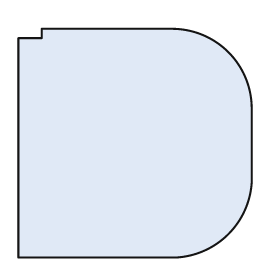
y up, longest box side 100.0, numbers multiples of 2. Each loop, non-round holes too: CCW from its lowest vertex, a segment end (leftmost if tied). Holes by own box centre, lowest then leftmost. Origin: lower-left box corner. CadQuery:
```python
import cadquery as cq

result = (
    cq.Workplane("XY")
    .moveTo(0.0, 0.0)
    .lineTo(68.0, 0.0)
    .threePointArc((90.0, 10.0), (100.0, 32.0))
    .lineTo(100.0, 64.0)
    .threePointArc((90.0, 88.0), (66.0, 98.0))
    .lineTo(10.0, 98.0)
    .lineTo(10.0, 94.0)
    .lineTo(0.0, 94.0)
    .close()
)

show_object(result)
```